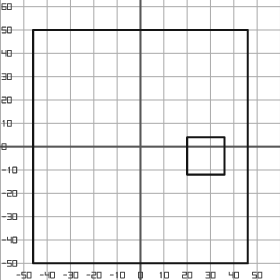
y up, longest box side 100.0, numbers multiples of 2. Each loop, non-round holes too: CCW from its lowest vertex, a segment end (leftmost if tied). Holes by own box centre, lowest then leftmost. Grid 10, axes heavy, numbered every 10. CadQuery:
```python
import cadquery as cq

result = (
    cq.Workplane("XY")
    .moveTo(-46.0, -50.0)
    .lineTo(46.0, -50.0)
    .lineTo(46.0, 50.0)
    .lineTo(-46.0, 50.0)
    .close()
    .moveTo(20.0, -12.0)
    .lineTo(36.0, -12.0)
    .lineTo(36.0, 4.0)
    .lineTo(20.0, 4.0)
    .close()
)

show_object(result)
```